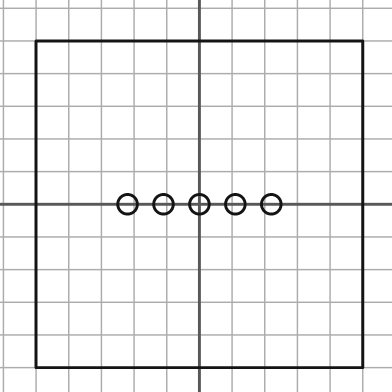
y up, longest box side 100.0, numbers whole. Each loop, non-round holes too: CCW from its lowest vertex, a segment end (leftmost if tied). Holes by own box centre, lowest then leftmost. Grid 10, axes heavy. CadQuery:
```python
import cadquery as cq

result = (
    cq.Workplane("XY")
    .moveTo(-50.0, -50.0)
    .lineTo(50.0, -50.0)
    .lineTo(50.0, 50.0)
    .lineTo(-50.0, 50.0)
    .close()
    .moveTo(-22.0, 0.0)
    .circle(3.0)
    .moveTo(-11.0, 0.0)
    .circle(3.0)
    .moveTo(0.0, 0.0)
    .circle(3.0)
    .moveTo(11.0, 0.0)
    .circle(3.0)
    .moveTo(22.0, 0.0)
    .circle(3.0)
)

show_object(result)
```